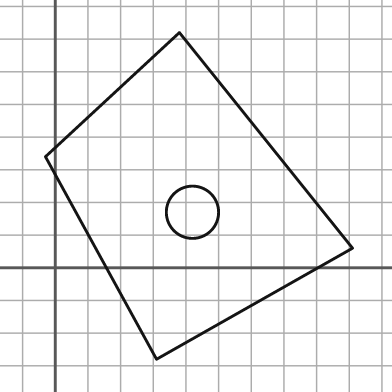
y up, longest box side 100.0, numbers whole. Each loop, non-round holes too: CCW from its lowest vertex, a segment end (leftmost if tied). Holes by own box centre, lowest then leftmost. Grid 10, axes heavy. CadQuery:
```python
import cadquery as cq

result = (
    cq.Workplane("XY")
    .moveTo(31.0, -28.0)
    .lineTo(91.0, 6.0)
    .lineTo(38.0, 72.0)
    .lineTo(-3.0, 34.0)
    .close()
    .moveTo(42.0, 17.0)
    .circle(8.0)
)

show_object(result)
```